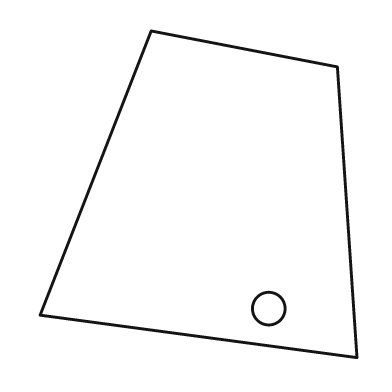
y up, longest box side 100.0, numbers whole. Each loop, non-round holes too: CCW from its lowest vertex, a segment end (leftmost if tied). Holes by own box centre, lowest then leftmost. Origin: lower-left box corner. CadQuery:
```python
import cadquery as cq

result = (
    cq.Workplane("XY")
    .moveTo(97.0, 0.0)
    .lineTo(91.0, 89.0)
    .lineTo(34.0, 100.0)
    .lineTo(0.0, 13.0)
    .close()
    .moveTo(70.0, 15.0)
    .circle(5.0)
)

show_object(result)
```